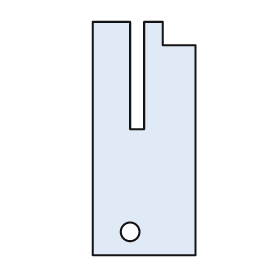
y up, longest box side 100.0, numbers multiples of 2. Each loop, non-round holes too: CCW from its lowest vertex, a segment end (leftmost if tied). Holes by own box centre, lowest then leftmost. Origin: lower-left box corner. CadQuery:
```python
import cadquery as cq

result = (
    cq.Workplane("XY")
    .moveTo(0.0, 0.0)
    .lineTo(44.0, 0.0)
    .lineTo(44.0, 90.0)
    .lineTo(30.0, 90.0)
    .lineTo(30.0, 100.0)
    .lineTo(22.0, 100.0)
    .lineTo(22.0, 54.0)
    .lineTo(16.0, 54.0)
    .lineTo(16.0, 100.0)
    .lineTo(0.0, 100.0)
    .close()
    .moveTo(16.0, 10.0)
    .circle(4.0)
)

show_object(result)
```